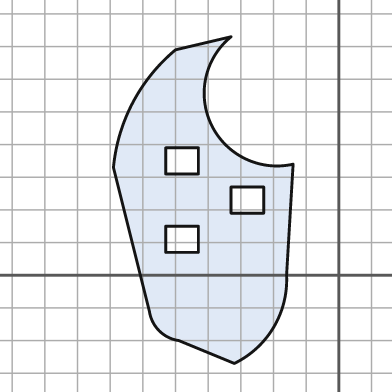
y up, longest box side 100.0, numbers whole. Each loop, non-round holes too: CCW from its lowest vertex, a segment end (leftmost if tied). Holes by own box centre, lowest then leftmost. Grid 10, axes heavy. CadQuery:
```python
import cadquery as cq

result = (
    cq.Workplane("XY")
    .moveTo(-32.0, -27.0)
    .threePointArc((-20.0, -16.0), (-16.0, 0.0))
    .lineTo(-14.0, 34.0)
    .threePointArc((-39.0, 46.0), (-33.0, 73.0))
    .lineTo(-50.0, 69.0)
    .threePointArc((-63.0, 53.0), (-69.0, 33.0))
    .lineTo(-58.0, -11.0)
    .threePointArc((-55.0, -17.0), (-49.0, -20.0))
    .close()
    .moveTo(-53.0, 7.0)
    .lineTo(-43.0, 7.0)
    .lineTo(-43.0, 15.0)
    .lineTo(-53.0, 15.0)
    .close()
    .moveTo(-33.0, 19.0)
    .lineTo(-23.0, 19.0)
    .lineTo(-23.0, 27.0)
    .lineTo(-33.0, 27.0)
    .close()
    .moveTo(-53.0, 31.0)
    .lineTo(-43.0, 31.0)
    .lineTo(-43.0, 39.0)
    .lineTo(-53.0, 39.0)
    .close()
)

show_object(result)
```